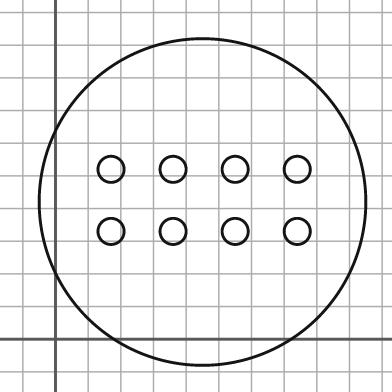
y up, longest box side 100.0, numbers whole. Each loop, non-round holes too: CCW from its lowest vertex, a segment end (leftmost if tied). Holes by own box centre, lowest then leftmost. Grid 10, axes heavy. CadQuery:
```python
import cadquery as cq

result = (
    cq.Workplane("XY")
    .moveTo(45.0, 42.0)
    .circle(50.0)
    .moveTo(17.0, 33.0)
    .circle(4.0)
    .moveTo(36.0, 33.0)
    .circle(4.0)
    .moveTo(55.0, 33.0)
    .circle(4.0)
    .moveTo(74.0, 33.0)
    .circle(4.0)
    .moveTo(17.0, 52.0)
    .circle(4.0)
    .moveTo(36.0, 52.0)
    .circle(4.0)
    .moveTo(55.0, 52.0)
    .circle(4.0)
    .moveTo(74.0, 52.0)
    .circle(4.0)
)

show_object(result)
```